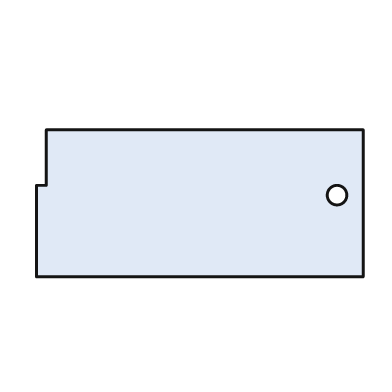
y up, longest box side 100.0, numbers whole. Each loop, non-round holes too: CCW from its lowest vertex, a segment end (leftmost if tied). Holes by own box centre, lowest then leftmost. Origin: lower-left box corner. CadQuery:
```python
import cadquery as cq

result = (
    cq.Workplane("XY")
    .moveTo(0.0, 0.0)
    .lineTo(100.0, 0.0)
    .lineTo(100.0, 45.0)
    .lineTo(3.0, 45.0)
    .lineTo(3.0, 28.0)
    .lineTo(0.0, 28.0)
    .close()
    .moveTo(92.0, 25.0)
    .circle(3.0)
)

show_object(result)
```